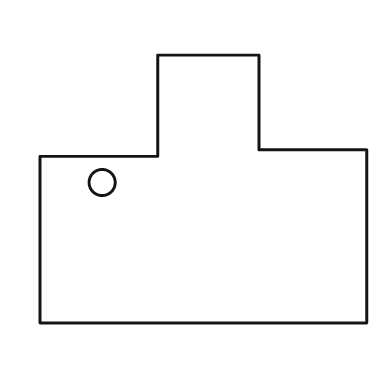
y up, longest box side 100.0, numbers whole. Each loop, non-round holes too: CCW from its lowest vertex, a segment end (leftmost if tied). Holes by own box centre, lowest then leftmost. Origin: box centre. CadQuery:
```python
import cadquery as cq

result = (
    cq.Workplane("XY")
    .moveTo(-50.0, -41.0)
    .lineTo(50.0, -41.0)
    .lineTo(50.0, 12.0)
    .lineTo(17.0, 12.0)
    .lineTo(17.0, 41.0)
    .lineTo(-14.0, 41.0)
    .lineTo(-14.0, 10.0)
    .lineTo(-50.0, 10.0)
    .close()
    .moveTo(-31.0, 2.0)
    .circle(4.0)
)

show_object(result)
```